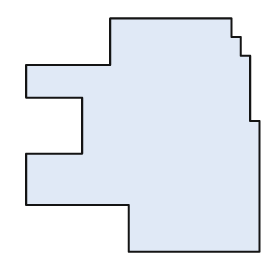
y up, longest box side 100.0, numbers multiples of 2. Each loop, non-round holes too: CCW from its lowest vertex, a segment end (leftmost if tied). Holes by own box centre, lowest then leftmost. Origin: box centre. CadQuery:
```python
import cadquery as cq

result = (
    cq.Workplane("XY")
    .moveTo(-6.0, -50.0)
    .lineTo(50.0, -50.0)
    .lineTo(50.0, 6.0)
    .lineTo(46.0, 6.0)
    .lineTo(46.0, 34.0)
    .lineTo(42.0, 34.0)
    .lineTo(42.0, 42.0)
    .lineTo(38.0, 42.0)
    .lineTo(38.0, 50.0)
    .lineTo(-14.0, 50.0)
    .lineTo(-14.0, 30.0)
    .lineTo(-50.0, 30.0)
    .lineTo(-50.0, 16.0)
    .lineTo(-26.0, 16.0)
    .lineTo(-26.0, -8.0)
    .lineTo(-50.0, -8.0)
    .lineTo(-50.0, -30.0)
    .lineTo(-6.0, -30.0)
    .close()
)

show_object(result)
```